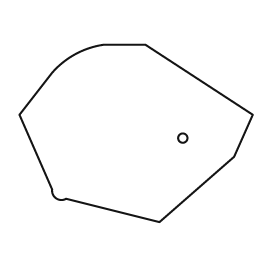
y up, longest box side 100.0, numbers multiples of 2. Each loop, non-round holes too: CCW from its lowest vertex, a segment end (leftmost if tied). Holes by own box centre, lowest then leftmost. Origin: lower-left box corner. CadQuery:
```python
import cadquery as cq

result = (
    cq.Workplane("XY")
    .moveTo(60.0, 0.0)
    .lineTo(92.0, 28.0)
    .lineTo(100.0, 46.0)
    .lineTo(54.0, 76.0)
    .lineTo(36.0, 76.0)
    .threePointArc((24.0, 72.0), (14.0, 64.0))
    .lineTo(0.0, 46.0)
    .lineTo(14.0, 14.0)
    .threePointArc((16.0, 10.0), (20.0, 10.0))
    .close()
    .moveTo(70.0, 36.0)
    .circle(2.0)
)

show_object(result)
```